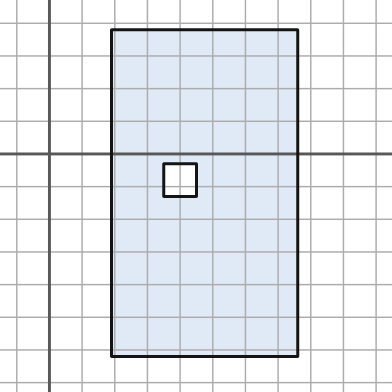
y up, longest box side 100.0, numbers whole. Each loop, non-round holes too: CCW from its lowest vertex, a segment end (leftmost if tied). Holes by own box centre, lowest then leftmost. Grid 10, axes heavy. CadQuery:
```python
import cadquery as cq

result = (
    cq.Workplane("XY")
    .moveTo(19.0, -62.0)
    .lineTo(76.0, -62.0)
    .lineTo(76.0, 38.0)
    .lineTo(19.0, 38.0)
    .close()
    .moveTo(35.0, -13.0)
    .lineTo(45.0, -13.0)
    .lineTo(45.0, -3.0)
    .lineTo(35.0, -3.0)
    .close()
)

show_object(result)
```